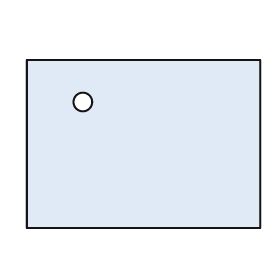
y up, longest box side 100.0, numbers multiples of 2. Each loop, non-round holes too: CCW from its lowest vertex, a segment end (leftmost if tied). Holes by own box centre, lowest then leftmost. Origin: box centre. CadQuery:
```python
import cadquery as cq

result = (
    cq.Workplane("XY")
    .moveTo(-50.0, -36.0)
    .lineTo(50.0, -36.0)
    .lineTo(50.0, 36.0)
    .lineTo(-50.0, 36.0)
    .close()
    .moveTo(-26.0, 18.0)
    .circle(4.0)
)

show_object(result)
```